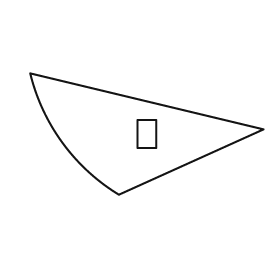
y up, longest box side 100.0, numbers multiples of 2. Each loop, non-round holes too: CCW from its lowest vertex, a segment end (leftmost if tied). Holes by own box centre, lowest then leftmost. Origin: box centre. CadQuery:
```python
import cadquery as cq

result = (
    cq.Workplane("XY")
    .moveTo(-12.0, -26.0)
    .lineTo(50.0, 2.0)
    .lineTo(-50.0, 26.0)
    .threePointArc((-36.0, -4.0), (-12.0, -26.0))
    .close()
    .moveTo(-4.0, -6.0)
    .lineTo(4.0, -6.0)
    .lineTo(4.0, 6.0)
    .lineTo(-4.0, 6.0)
    .close()
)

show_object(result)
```